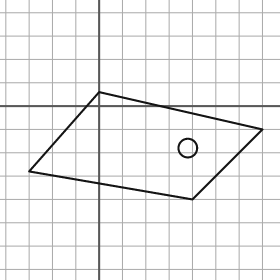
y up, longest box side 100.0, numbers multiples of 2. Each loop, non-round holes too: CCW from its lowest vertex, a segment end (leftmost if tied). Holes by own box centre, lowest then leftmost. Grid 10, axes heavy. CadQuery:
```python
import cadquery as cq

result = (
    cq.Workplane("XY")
    .moveTo(40.0, -40.0)
    .lineTo(70.0, -10.0)
    .lineTo(0.0, 6.0)
    .lineTo(-30.0, -28.0)
    .close()
    .moveTo(38.0, -18.0)
    .circle(4.0)
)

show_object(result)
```